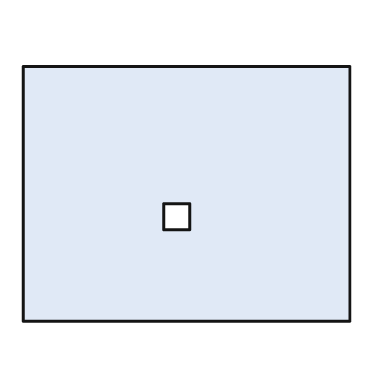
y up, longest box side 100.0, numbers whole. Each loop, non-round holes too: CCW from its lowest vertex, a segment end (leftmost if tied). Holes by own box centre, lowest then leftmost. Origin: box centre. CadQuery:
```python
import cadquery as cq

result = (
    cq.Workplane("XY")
    .moveTo(-50.0, -39.0)
    .lineTo(50.0, -39.0)
    .lineTo(50.0, 39.0)
    .lineTo(-50.0, 39.0)
    .close()
    .moveTo(-7.0, -11.0)
    .lineTo(1.0, -11.0)
    .lineTo(1.0, -3.0)
    .lineTo(-7.0, -3.0)
    .close()
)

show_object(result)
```